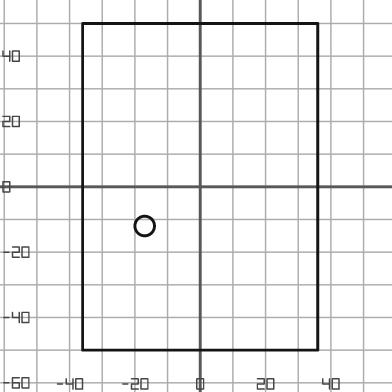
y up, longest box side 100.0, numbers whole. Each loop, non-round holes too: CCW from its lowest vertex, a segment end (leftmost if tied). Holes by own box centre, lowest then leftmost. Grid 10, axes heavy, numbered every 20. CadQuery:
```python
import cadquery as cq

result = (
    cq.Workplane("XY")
    .moveTo(-36.0, -50.0)
    .lineTo(36.0, -50.0)
    .lineTo(36.0, 50.0)
    .lineTo(-36.0, 50.0)
    .close()
    .moveTo(-17.0, -12.0)
    .circle(3.0)
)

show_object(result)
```